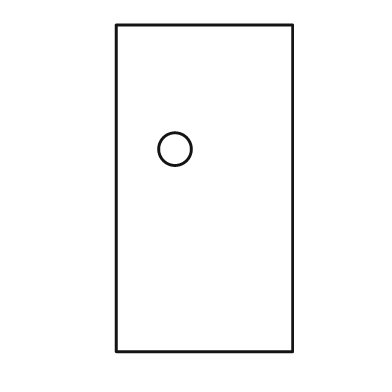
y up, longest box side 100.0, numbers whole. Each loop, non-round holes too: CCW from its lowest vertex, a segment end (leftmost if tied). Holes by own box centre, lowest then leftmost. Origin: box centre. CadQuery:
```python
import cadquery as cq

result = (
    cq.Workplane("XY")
    .moveTo(-27.0, -50.0)
    .lineTo(27.0, -50.0)
    .lineTo(27.0, 50.0)
    .lineTo(-27.0, 50.0)
    .close()
    .moveTo(-9.0, 12.0)
    .circle(5.0)
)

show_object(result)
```